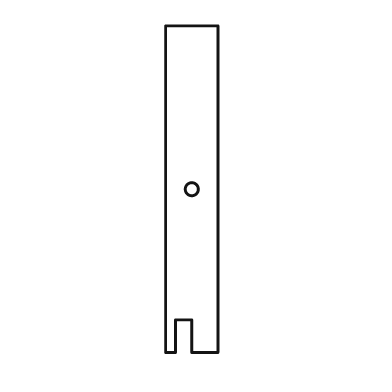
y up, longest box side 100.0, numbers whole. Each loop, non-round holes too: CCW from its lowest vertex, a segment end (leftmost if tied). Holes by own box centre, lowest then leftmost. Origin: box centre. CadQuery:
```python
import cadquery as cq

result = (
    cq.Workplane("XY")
    .moveTo(-8.0, -50.0)
    .lineTo(-5.0, -50.0)
    .lineTo(-5.0, -40.0)
    .lineTo(0.0, -40.0)
    .lineTo(0.0, -50.0)
    .lineTo(8.0, -50.0)
    .lineTo(8.0, 50.0)
    .lineTo(-8.0, 50.0)
    .close()
    .moveTo(0.0, 0.0)
    .circle(2.0)
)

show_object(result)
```